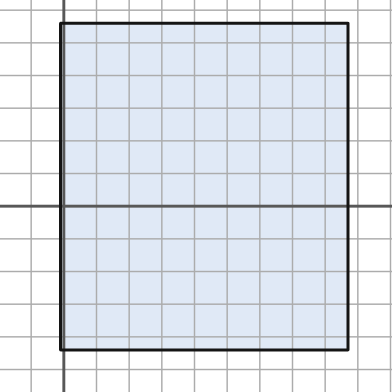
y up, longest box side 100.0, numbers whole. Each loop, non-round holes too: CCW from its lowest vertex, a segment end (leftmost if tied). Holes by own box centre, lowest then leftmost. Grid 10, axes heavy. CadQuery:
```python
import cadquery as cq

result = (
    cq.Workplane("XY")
    .moveTo(-1.0, -44.0)
    .lineTo(87.0, -44.0)
    .lineTo(87.0, 56.0)
    .lineTo(-1.0, 56.0)
    .close()
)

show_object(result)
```